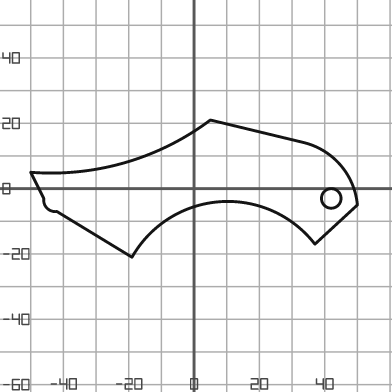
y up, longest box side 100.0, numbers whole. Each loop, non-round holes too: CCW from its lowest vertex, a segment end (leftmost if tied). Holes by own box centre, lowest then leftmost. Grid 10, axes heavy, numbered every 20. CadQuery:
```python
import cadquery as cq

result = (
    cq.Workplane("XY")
    .moveTo(-19.0, -21.0)
    .threePointArc((8.0, -4.0), (37.0, -17.0))
    .lineTo(50.0, -5.0)
    .threePointArc((45.0, 7.0), (34.0, 14.0))
    .lineTo(5.0, 21.0)
    .threePointArc((-21.0, 8.0), (-50.0, 5.0))
    .lineTo(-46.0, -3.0)
    .threePointArc((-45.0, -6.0), (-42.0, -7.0))
    .close()
    .moveTo(42.0, -3.0)
    .circle(3.0)
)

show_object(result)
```